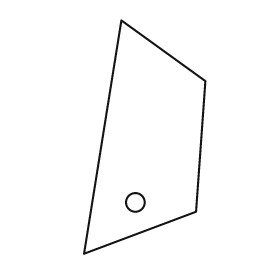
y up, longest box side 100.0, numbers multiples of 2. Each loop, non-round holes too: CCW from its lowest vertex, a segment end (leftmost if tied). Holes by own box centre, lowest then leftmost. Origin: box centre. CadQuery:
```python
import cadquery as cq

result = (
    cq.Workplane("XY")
    .moveTo(-26.0, -50.0)
    .lineTo(22.0, -32.0)
    .lineTo(26.0, 24.0)
    .lineTo(-10.0, 50.0)
    .close()
    .moveTo(-4.0, -28.0)
    .circle(4.0)
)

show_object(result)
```